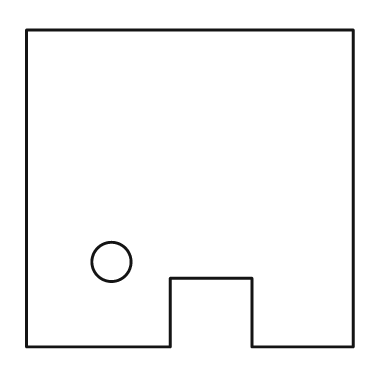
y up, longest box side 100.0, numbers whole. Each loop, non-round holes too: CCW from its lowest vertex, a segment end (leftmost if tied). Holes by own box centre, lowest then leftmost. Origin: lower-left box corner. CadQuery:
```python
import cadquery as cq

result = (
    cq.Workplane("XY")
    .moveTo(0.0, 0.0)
    .lineTo(44.0, 0.0)
    .lineTo(44.0, 21.0)
    .lineTo(69.0, 21.0)
    .lineTo(69.0, 0.0)
    .lineTo(100.0, 0.0)
    .lineTo(100.0, 97.0)
    .lineTo(0.0, 97.0)
    .close()
    .moveTo(26.0, 26.0)
    .circle(6.0)
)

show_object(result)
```